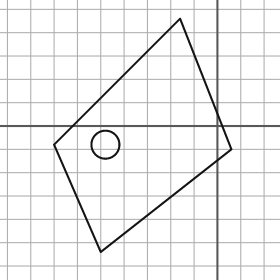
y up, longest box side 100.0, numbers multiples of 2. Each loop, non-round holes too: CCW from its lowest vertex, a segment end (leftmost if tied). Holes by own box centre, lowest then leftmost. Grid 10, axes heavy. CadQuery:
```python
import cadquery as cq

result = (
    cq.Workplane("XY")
    .moveTo(-50.0, -54.0)
    .lineTo(6.0, -10.0)
    .lineTo(-16.0, 46.0)
    .lineTo(-70.0, -8.0)
    .close()
    .moveTo(-48.0, -8.0)
    .circle(6.0)
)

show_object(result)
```